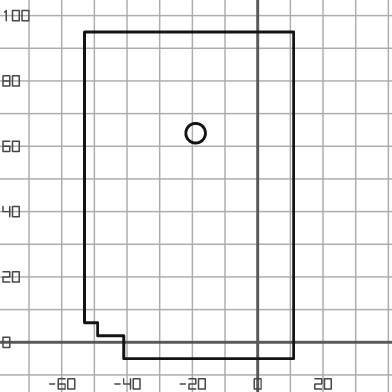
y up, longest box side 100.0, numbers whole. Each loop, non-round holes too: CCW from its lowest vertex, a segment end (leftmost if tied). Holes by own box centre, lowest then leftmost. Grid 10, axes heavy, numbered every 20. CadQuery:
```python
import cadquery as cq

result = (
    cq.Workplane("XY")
    .moveTo(-41.0, -5.0)
    .lineTo(11.0, -5.0)
    .lineTo(11.0, 95.0)
    .lineTo(-53.0, 95.0)
    .lineTo(-53.0, 6.0)
    .lineTo(-49.0, 6.0)
    .lineTo(-49.0, 2.0)
    .lineTo(-41.0, 2.0)
    .close()
    .moveTo(-19.0, 64.0)
    .circle(3.0)
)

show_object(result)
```